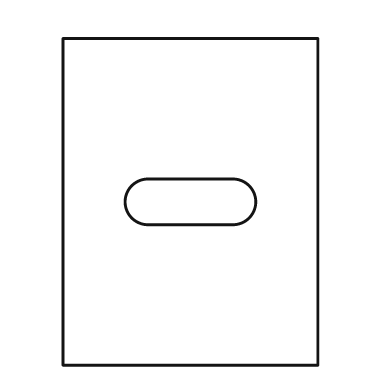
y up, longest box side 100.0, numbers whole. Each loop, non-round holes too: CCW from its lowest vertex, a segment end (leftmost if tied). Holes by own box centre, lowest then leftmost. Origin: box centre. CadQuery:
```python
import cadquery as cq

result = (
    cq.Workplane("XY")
    .moveTo(-39.0, -50.0)
    .lineTo(39.0, -50.0)
    .lineTo(39.0, 50.0)
    .lineTo(-39.0, 50.0)
    .close()
    .moveTo(-13.0, -7.0)
    .lineTo(13.0, -7.0)
    .threePointArc((20.0, 0.0), (13.0, 7.0))
    .lineTo(-13.0, 7.0)
    .threePointArc((-20.0, 0.0), (-13.0, -7.0))
    .close()
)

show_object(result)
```